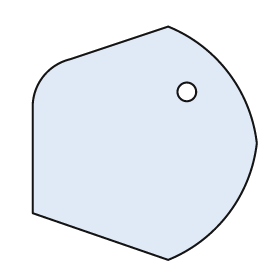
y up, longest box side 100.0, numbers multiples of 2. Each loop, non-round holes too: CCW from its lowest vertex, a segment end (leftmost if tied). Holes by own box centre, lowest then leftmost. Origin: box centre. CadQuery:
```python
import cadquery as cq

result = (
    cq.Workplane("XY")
    .moveTo(10.0, -50.0)
    .threePointArc((36.0, -30.0), (48.0, 0.0))
    .threePointArc((36.0, 30.0), (10.0, 50.0))
    .lineTo(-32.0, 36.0)
    .threePointArc((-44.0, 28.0), (-48.0, 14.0))
    .lineTo(-48.0, -30.0)
    .close()
    .moveTo(18.0, 22.0)
    .circle(4.0)
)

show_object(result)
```